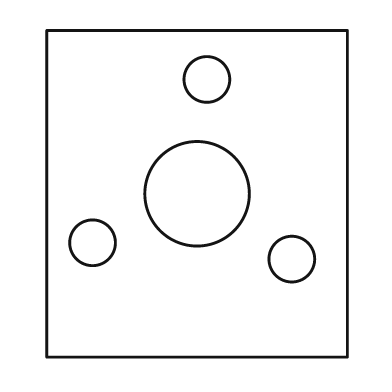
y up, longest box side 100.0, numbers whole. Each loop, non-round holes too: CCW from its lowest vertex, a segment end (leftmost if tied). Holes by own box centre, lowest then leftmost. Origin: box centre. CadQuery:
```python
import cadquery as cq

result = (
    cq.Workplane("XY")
    .moveTo(-46.0, -50.0)
    .lineTo(46.0, -50.0)
    .lineTo(46.0, 50.0)
    .lineTo(-46.0, 50.0)
    .close()
    .moveTo(29.0, -20.0)
    .circle(7.0)
    .moveTo(-32.0, -15.0)
    .circle(7.0)
    .moveTo(0.0, 0.0)
    .circle(16.0)
    .moveTo(3.0, 35.0)
    .circle(7.0)
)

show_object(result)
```